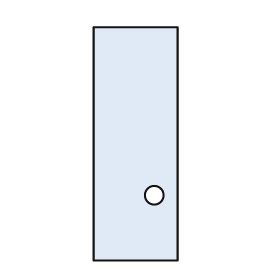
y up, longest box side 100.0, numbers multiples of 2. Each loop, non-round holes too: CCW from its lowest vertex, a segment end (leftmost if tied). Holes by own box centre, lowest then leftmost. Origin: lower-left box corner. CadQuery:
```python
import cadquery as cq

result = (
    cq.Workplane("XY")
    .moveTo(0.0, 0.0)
    .lineTo(36.0, 0.0)
    .lineTo(36.0, 100.0)
    .lineTo(0.0, 100.0)
    .close()
    .moveTo(26.0, 28.0)
    .circle(4.0)
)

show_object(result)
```